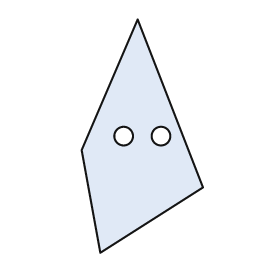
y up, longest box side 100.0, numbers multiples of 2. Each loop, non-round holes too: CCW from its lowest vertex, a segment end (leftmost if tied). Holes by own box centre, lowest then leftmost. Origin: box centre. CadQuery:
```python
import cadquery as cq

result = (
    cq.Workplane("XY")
    .moveTo(-18.0, -50.0)
    .lineTo(26.0, -22.0)
    .lineTo(-2.0, 50.0)
    .lineTo(-26.0, -6.0)
    .close()
    .moveTo(-8.0, 0.0)
    .circle(4.0)
    .moveTo(8.0, 0.0)
    .circle(4.0)
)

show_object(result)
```